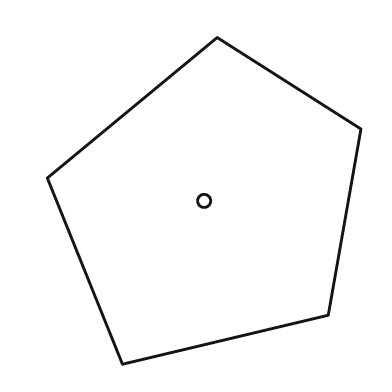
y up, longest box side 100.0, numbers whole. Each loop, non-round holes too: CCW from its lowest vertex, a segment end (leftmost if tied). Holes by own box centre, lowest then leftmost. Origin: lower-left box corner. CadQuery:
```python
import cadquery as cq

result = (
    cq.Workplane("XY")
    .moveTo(23.0, 0.0)
    .lineTo(86.0, 15.0)
    .lineTo(96.0, 72.0)
    .lineTo(52.0, 100.0)
    .lineTo(0.0, 57.0)
    .close()
    .moveTo(48.0, 50.0)
    .circle(2.0)
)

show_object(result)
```